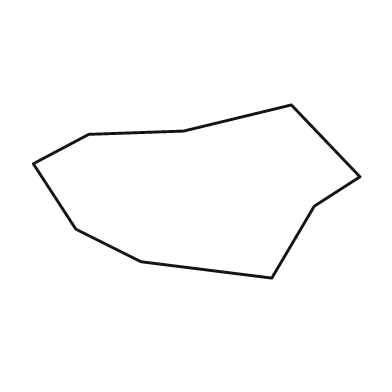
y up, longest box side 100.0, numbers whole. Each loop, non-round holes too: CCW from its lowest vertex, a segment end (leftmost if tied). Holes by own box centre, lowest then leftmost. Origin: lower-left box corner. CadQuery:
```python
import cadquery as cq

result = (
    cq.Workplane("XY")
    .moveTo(73.0, 0.0)
    .lineTo(86.0, 22.0)
    .lineTo(100.0, 31.0)
    .lineTo(79.0, 53.0)
    .lineTo(46.0, 45.0)
    .lineTo(17.0, 44.0)
    .lineTo(0.0, 35.0)
    .lineTo(13.0, 15.0)
    .lineTo(33.0, 5.0)
    .close()
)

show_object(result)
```